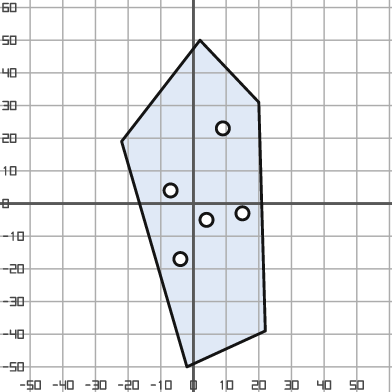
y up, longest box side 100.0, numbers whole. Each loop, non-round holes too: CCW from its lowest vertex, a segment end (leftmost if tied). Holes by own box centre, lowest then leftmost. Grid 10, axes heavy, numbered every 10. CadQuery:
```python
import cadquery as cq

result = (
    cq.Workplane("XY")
    .moveTo(-2.0, -50.0)
    .lineTo(22.0, -39.0)
    .lineTo(20.0, 31.0)
    .lineTo(2.0, 50.0)
    .lineTo(-22.0, 19.0)
    .close()
    .moveTo(-4.0, -17.0)
    .circle(2.0)
    .moveTo(4.0, -5.0)
    .circle(2.0)
    .moveTo(15.0, -3.0)
    .circle(2.0)
    .moveTo(-7.0, 4.0)
    .circle(2.0)
    .moveTo(9.0, 23.0)
    .circle(2.0)
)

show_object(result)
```